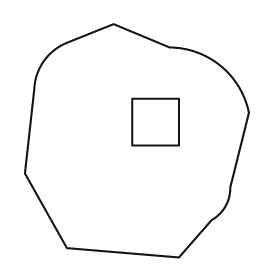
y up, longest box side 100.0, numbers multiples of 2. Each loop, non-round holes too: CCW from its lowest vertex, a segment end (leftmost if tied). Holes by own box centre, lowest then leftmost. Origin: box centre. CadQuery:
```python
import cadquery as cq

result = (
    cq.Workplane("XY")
    .moveTo(18.0, -50.0)
    .lineTo(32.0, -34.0)
    .threePointArc((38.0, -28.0), (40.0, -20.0))
    .lineTo(48.0, 12.0)
    .threePointArc((36.0, 32.0), (14.0, 40.0))
    .lineTo(-10.0, 50.0)
    .lineTo(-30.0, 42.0)
    .threePointArc((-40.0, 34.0), (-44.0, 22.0))
    .lineTo(-48.0, -14.0)
    .lineTo(-30.0, -46.0)
    .close()
    .moveTo(-2.0, -2.0)
    .lineTo(18.0, -2.0)
    .lineTo(18.0, 18.0)
    .lineTo(-2.0, 18.0)
    .close()
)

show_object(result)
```